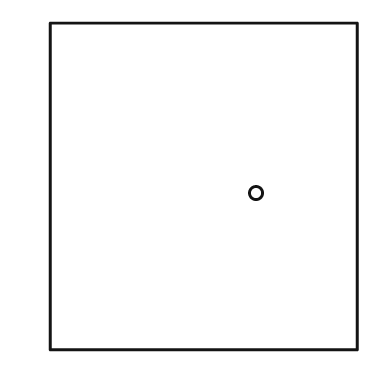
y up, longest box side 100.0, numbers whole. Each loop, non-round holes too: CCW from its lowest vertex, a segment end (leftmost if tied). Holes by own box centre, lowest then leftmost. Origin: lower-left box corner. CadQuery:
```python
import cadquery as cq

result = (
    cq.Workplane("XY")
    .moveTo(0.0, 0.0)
    .lineTo(94.0, 0.0)
    .lineTo(94.0, 100.0)
    .lineTo(0.0, 100.0)
    .close()
    .moveTo(63.0, 48.0)
    .circle(2.0)
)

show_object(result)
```